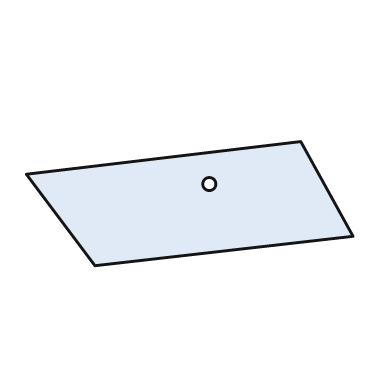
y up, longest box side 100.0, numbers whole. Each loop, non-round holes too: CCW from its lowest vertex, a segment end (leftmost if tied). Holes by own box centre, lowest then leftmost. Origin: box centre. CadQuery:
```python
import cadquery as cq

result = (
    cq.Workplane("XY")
    .moveTo(-29.0, -19.0)
    .lineTo(50.0, -10.0)
    .lineTo(34.0, 19.0)
    .lineTo(-50.0, 9.0)
    .close()
    .moveTo(6.0, 6.0)
    .circle(2.0)
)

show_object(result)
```